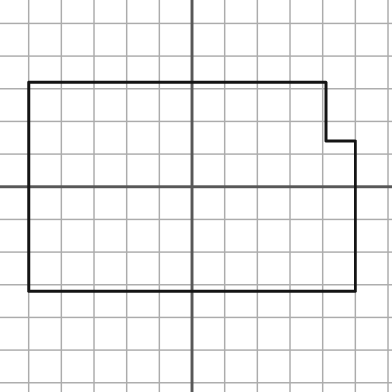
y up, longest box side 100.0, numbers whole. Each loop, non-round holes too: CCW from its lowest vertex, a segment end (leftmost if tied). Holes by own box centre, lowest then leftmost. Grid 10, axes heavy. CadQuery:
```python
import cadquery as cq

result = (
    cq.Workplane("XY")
    .moveTo(-50.0, -32.0)
    .lineTo(50.0, -32.0)
    .lineTo(50.0, 14.0)
    .lineTo(41.0, 14.0)
    .lineTo(41.0, 32.0)
    .lineTo(-50.0, 32.0)
    .close()
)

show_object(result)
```